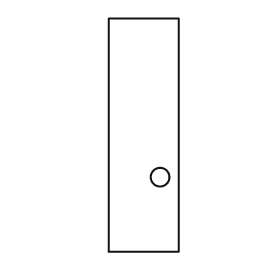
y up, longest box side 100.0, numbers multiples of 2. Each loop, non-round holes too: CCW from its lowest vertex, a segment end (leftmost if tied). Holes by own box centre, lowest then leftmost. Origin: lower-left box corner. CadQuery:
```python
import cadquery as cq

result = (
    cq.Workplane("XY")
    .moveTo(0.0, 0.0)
    .lineTo(30.0, 0.0)
    .lineTo(30.0, 100.0)
    .lineTo(0.0, 100.0)
    .close()
    .moveTo(22.0, 32.0)
    .circle(4.0)
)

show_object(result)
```